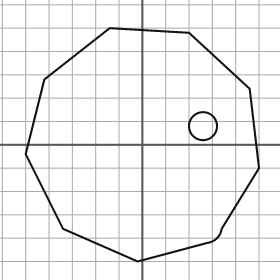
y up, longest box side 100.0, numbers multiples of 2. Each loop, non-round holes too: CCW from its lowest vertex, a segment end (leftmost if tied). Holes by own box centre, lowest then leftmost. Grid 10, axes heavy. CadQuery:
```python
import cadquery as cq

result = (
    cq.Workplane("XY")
    .moveTo(-2.0, -50.0)
    .lineTo(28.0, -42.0)
    .threePointArc((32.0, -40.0), (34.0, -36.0))
    .lineTo(50.0, -10.0)
    .lineTo(46.0, 24.0)
    .lineTo(20.0, 48.0)
    .lineTo(-14.0, 50.0)
    .lineTo(-42.0, 28.0)
    .lineTo(-50.0, -4.0)
    .lineTo(-34.0, -36.0)
    .close()
    .moveTo(26.0, 8.0)
    .circle(6.0)
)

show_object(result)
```